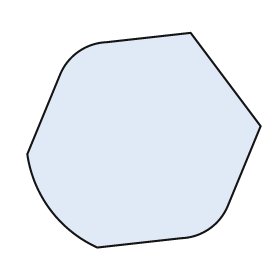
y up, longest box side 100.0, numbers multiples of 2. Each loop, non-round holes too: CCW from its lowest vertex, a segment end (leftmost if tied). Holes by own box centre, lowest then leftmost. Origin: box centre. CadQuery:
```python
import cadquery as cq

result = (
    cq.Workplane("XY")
    .moveTo(-20.0, -46.0)
    .lineTo(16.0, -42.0)
    .threePointArc((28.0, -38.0), (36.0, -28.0))
    .lineTo(50.0, 6.0)
    .lineTo(20.0, 46.0)
    .lineTo(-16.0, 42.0)
    .threePointArc((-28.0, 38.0), (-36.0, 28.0))
    .lineTo(-50.0, -6.0)
    .threePointArc((-40.0, -30.0), (-20.0, -46.0))
    .close()
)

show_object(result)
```